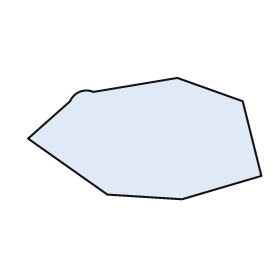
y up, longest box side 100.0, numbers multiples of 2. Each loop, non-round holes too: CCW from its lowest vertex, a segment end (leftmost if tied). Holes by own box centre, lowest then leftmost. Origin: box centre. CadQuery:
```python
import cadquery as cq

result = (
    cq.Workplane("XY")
    .moveTo(16.0, -26.0)
    .lineTo(50.0, -16.0)
    .lineTo(42.0, 16.0)
    .lineTo(14.0, 26.0)
    .lineTo(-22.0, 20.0)
    .threePointArc((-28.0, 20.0), (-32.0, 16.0))
    .lineTo(-50.0, 0.0)
    .lineTo(-16.0, -24.0)
    .close()
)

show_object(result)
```